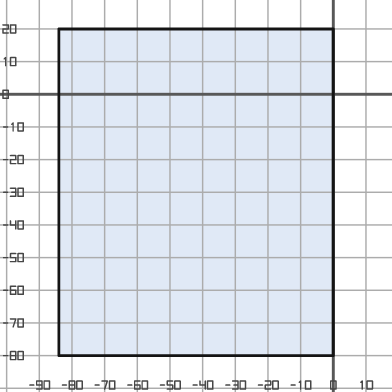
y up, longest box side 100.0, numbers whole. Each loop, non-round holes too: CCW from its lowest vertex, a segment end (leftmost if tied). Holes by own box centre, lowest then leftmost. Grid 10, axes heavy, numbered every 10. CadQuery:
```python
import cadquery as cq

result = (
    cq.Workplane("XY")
    .moveTo(-84.0, -80.0)
    .lineTo(0.0, -80.0)
    .lineTo(0.0, 20.0)
    .lineTo(-84.0, 20.0)
    .close()
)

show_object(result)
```